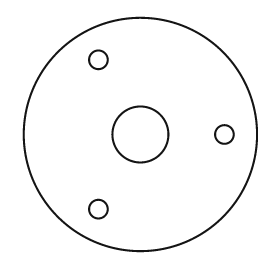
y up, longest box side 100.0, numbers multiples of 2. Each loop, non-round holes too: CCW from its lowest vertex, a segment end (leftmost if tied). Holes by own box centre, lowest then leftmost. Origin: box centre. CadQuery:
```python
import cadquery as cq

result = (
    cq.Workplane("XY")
    .moveTo(0.0, 0.0)
    .circle(50.0)
    .moveTo(-18.0, -32.0)
    .circle(4.0)
    .moveTo(0.0, 0.0)
    .circle(12.0)
    .moveTo(36.0, 0.0)
    .circle(4.0)
    .moveTo(-18.0, 32.0)
    .circle(4.0)
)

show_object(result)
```